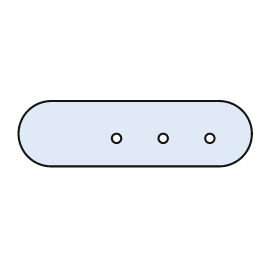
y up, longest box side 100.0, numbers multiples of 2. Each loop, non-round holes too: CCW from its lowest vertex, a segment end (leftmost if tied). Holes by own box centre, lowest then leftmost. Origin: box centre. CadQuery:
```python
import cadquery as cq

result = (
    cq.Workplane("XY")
    .moveTo(-36.0, -14.0)
    .lineTo(36.0, -14.0)
    .threePointArc((50.0, 0.0), (36.0, 14.0))
    .lineTo(-36.0, 14.0)
    .threePointArc((-50.0, 0.0), (-36.0, -14.0))
    .close()
    .moveTo(-8.0, -2.0)
    .circle(2.0)
    .moveTo(12.0, -2.0)
    .circle(2.0)
    .moveTo(32.0, -2.0)
    .circle(2.0)
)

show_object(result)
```